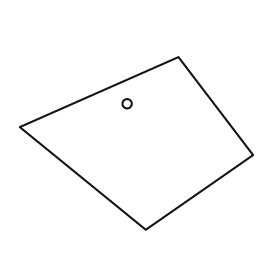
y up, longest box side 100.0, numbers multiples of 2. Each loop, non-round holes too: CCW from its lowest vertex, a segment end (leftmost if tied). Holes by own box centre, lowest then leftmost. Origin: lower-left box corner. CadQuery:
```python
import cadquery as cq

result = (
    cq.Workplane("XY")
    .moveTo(54.0, 0.0)
    .lineTo(100.0, 32.0)
    .lineTo(68.0, 74.0)
    .lineTo(0.0, 44.0)
    .close()
    .moveTo(46.0, 54.0)
    .circle(2.0)
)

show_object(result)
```